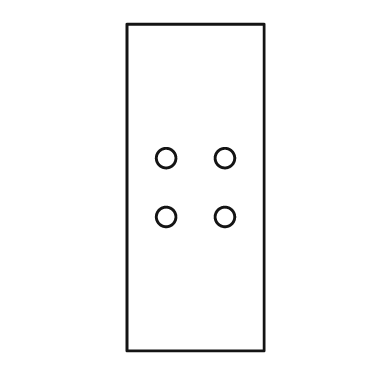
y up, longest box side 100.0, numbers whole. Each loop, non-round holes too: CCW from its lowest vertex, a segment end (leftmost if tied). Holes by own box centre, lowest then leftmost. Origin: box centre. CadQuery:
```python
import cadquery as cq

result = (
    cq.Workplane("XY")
    .moveTo(-21.0, -50.0)
    .lineTo(21.0, -50.0)
    .lineTo(21.0, 50.0)
    .lineTo(-21.0, 50.0)
    .close()
    .moveTo(-9.0, -9.0)
    .circle(3.0)
    .moveTo(9.0, -9.0)
    .circle(3.0)
    .moveTo(-9.0, 9.0)
    .circle(3.0)
    .moveTo(9.0, 9.0)
    .circle(3.0)
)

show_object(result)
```